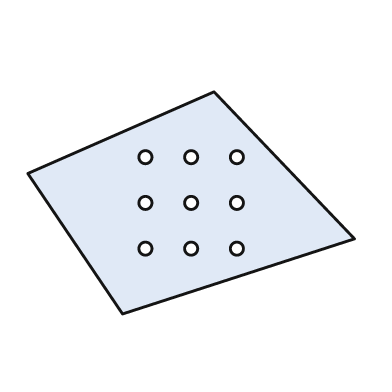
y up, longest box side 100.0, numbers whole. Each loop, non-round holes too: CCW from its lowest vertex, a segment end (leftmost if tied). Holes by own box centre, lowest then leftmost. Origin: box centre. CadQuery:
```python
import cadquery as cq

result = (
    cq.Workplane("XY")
    .moveTo(-21.0, -34.0)
    .lineTo(50.0, -11.0)
    .lineTo(7.0, 34.0)
    .lineTo(-50.0, 9.0)
    .close()
    .moveTo(-14.0, -14.0)
    .circle(2.0)
    .moveTo(0.0, -14.0)
    .circle(2.0)
    .moveTo(14.0, -14.0)
    .circle(2.0)
    .moveTo(-14.0, 0.0)
    .circle(2.0)
    .moveTo(0.0, 0.0)
    .circle(2.0)
    .moveTo(14.0, 0.0)
    .circle(2.0)
    .moveTo(-14.0, 14.0)
    .circle(2.0)
    .moveTo(0.0, 14.0)
    .circle(2.0)
    .moveTo(14.0, 14.0)
    .circle(2.0)
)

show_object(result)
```